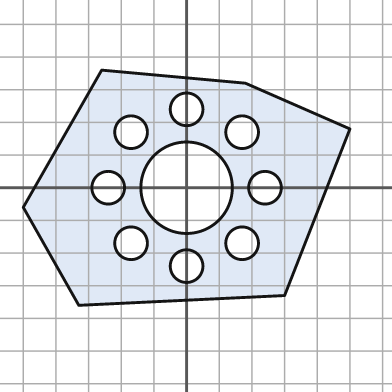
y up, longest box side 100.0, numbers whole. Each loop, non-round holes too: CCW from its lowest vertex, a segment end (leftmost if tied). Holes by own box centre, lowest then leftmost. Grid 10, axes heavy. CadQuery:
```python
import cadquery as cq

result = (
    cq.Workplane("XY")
    .moveTo(-33.0, -36.0)
    .lineTo(30.0, -33.0)
    .lineTo(50.0, 18.0)
    .lineTo(18.0, 32.0)
    .lineTo(-26.0, 36.0)
    .lineTo(-50.0, -6.0)
    .close()
    .moveTo(0.0, -24.0)
    .circle(5.0)
    .moveTo(-17.0, -17.0)
    .circle(5.0)
    .moveTo(17.0, -17.0)
    .circle(5.0)
    .moveTo(-24.0, 0.0)
    .circle(5.0)
    .moveTo(0.0, 0.0)
    .circle(14.0)
    .moveTo(24.0, 0.0)
    .circle(5.0)
    .moveTo(-17.0, 17.0)
    .circle(5.0)
    .moveTo(17.0, 17.0)
    .circle(5.0)
    .moveTo(0.0, 24.0)
    .circle(5.0)
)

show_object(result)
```